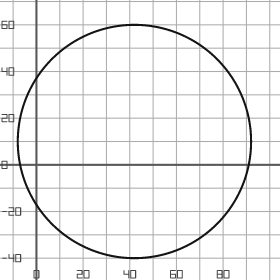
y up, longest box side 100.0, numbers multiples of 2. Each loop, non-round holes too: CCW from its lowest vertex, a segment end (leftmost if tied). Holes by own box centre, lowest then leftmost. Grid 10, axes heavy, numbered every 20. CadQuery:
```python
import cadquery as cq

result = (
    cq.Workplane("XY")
    .moveTo(42.0, 10.0)
    .circle(50.0)
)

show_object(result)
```